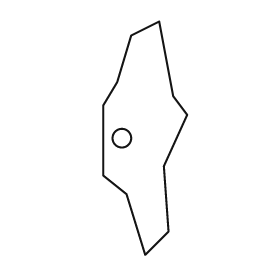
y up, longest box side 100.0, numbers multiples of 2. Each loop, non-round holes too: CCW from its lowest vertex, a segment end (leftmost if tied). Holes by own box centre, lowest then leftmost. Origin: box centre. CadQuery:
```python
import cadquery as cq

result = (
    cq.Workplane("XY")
    .moveTo(0.0, -50.0)
    .lineTo(10.0, -40.0)
    .lineTo(8.0, -12.0)
    .lineTo(18.0, 10.0)
    .lineTo(12.0, 18.0)
    .lineTo(6.0, 50.0)
    .lineTo(-6.0, 44.0)
    .lineTo(-12.0, 24.0)
    .lineTo(-18.0, 14.0)
    .lineTo(-18.0, -16.0)
    .lineTo(-8.0, -24.0)
    .close()
    .moveTo(-10.0, 0.0)
    .circle(4.0)
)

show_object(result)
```